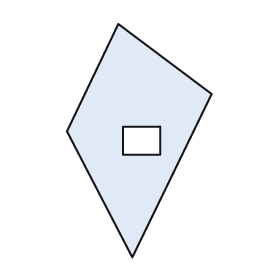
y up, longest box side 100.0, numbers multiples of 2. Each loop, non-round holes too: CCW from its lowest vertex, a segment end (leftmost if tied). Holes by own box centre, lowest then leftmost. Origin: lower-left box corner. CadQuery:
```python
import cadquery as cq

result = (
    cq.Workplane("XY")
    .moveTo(28.0, 0.0)
    .lineTo(62.0, 70.0)
    .lineTo(22.0, 100.0)
    .lineTo(0.0, 54.0)
    .close()
    .moveTo(24.0, 44.0)
    .lineTo(40.0, 44.0)
    .lineTo(40.0, 56.0)
    .lineTo(24.0, 56.0)
    .close()
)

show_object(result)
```